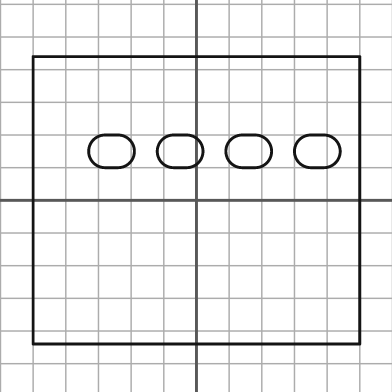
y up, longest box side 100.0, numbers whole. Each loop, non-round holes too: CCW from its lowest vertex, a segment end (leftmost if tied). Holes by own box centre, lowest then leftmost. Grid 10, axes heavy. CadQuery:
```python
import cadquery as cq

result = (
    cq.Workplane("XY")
    .moveTo(-50.0, -44.0)
    .lineTo(50.0, -44.0)
    .lineTo(50.0, 44.0)
    .lineTo(-50.0, 44.0)
    .close()
    .moveTo(-28.0, 10.0)
    .lineTo(-24.0, 10.0)
    .threePointArc((-19.0, 15.0), (-24.0, 20.0))
    .lineTo(-28.0, 20.0)
    .threePointArc((-33.0, 15.0), (-28.0, 10.0))
    .close()
    .moveTo(-7.0, 10.0)
    .lineTo(-3.0, 10.0)
    .threePointArc((2.0, 15.0), (-3.0, 20.0))
    .lineTo(-7.0, 20.0)
    .threePointArc((-12.0, 15.0), (-7.0, 10.0))
    .close()
    .moveTo(14.0, 10.0)
    .lineTo(18.0, 10.0)
    .threePointArc((23.0, 15.0), (18.0, 20.0))
    .lineTo(14.0, 20.0)
    .threePointArc((9.0, 15.0), (14.0, 10.0))
    .close()
    .moveTo(35.0, 10.0)
    .lineTo(39.0, 10.0)
    .threePointArc((44.0, 15.0), (39.0, 20.0))
    .lineTo(35.0, 20.0)
    .threePointArc((30.0, 15.0), (35.0, 10.0))
    .close()
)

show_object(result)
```